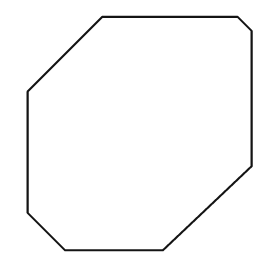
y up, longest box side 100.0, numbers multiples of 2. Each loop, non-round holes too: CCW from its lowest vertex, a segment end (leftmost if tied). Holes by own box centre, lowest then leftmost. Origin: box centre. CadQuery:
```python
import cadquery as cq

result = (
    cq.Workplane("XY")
    .moveTo(-32.0, -50.0)
    .lineTo(10.0, -50.0)
    .lineTo(48.0, -14.0)
    .lineTo(48.0, 44.0)
    .lineTo(42.0, 50.0)
    .lineTo(-16.0, 50.0)
    .lineTo(-48.0, 18.0)
    .lineTo(-48.0, -34.0)
    .close()
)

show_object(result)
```